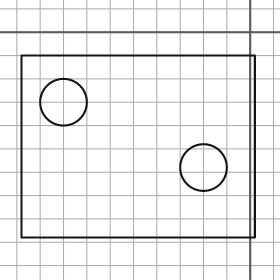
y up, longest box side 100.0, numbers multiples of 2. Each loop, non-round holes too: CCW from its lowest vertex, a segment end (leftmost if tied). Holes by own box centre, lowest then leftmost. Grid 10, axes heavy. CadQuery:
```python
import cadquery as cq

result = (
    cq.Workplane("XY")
    .moveTo(-98.0, -88.0)
    .lineTo(2.0, -88.0)
    .lineTo(2.0, -10.0)
    .lineTo(-98.0, -10.0)
    .close()
    .moveTo(-20.0, -58.0)
    .circle(10.0)
    .moveTo(-80.0, -30.0)
    .circle(10.0)
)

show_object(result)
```